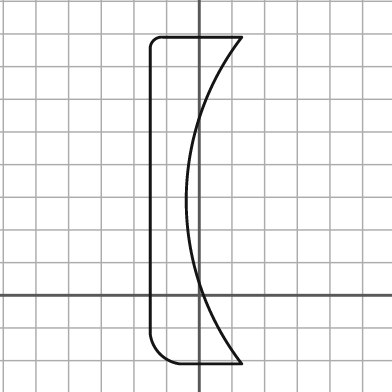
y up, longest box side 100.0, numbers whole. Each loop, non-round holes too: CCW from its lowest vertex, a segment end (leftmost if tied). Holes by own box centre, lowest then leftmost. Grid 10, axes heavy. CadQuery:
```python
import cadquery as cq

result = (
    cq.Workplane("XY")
    .moveTo(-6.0, -21.0)
    .lineTo(13.0, -21.0)
    .threePointArc((-4.0, 29.0), (13.0, 79.0))
    .lineTo(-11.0, 79.0)
    .threePointArc((-14.0, 78.0), (-15.0, 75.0))
    .lineTo(-15.0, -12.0)
    .threePointArc((-12.0, -18.0), (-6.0, -21.0))
    .close()
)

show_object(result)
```